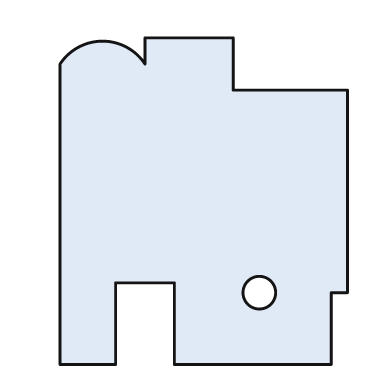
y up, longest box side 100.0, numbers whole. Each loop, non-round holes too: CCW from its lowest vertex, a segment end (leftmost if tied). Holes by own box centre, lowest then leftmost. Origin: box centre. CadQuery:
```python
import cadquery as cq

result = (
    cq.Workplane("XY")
    .moveTo(-44.0, -50.0)
    .lineTo(-27.0, -50.0)
    .lineTo(-27.0, -25.0)
    .lineTo(-9.0, -25.0)
    .lineTo(-9.0, -50.0)
    .lineTo(39.0, -50.0)
    .lineTo(39.0, -28.0)
    .lineTo(44.0, -28.0)
    .lineTo(44.0, 34.0)
    .lineTo(9.0, 34.0)
    .lineTo(9.0, 50.0)
    .lineTo(-18.0, 50.0)
    .lineTo(-18.0, 42.0)
    .threePointArc((-31.0, 49.0), (-44.0, 42.0))
    .close()
    .moveTo(17.0, -28.0)
    .circle(5.0)
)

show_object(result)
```